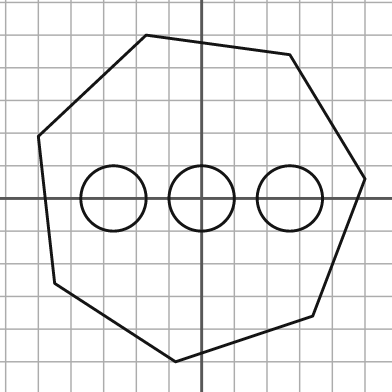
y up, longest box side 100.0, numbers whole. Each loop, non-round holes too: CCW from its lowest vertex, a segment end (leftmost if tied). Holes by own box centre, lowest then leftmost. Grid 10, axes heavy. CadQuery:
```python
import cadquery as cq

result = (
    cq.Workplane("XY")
    .moveTo(-8.0, -50.0)
    .lineTo(34.0, -36.0)
    .lineTo(50.0, 6.0)
    .lineTo(27.0, 44.0)
    .lineTo(-17.0, 50.0)
    .lineTo(-50.0, 19.0)
    .lineTo(-45.0, -26.0)
    .close()
    .moveTo(-27.0, 0.0)
    .circle(10.0)
    .moveTo(0.0, 0.0)
    .circle(10.0)
    .moveTo(27.0, 0.0)
    .circle(10.0)
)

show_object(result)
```